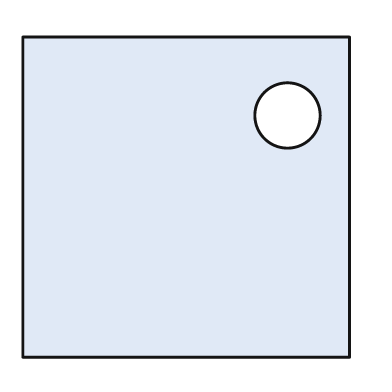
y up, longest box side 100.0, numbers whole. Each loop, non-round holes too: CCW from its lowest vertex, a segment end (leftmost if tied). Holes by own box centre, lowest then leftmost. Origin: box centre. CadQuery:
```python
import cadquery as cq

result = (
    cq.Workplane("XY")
    .moveTo(-50.0, -49.0)
    .lineTo(50.0, -49.0)
    .lineTo(50.0, 49.0)
    .lineTo(-50.0, 49.0)
    .close()
    .moveTo(31.0, 25.0)
    .circle(10.0)
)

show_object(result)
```